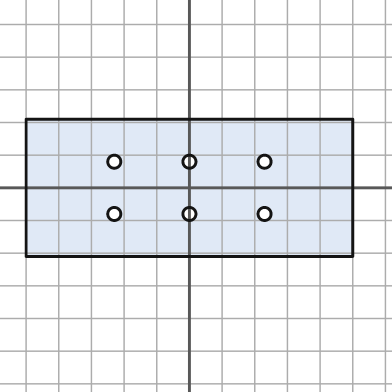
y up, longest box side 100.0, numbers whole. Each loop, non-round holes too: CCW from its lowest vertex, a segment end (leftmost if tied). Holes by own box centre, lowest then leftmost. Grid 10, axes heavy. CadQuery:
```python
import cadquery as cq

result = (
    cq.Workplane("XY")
    .moveTo(-50.0, -21.0)
    .lineTo(50.0, -21.0)
    .lineTo(50.0, 21.0)
    .lineTo(-50.0, 21.0)
    .close()
    .moveTo(-23.0, -8.0)
    .circle(2.0)
    .moveTo(0.0, -8.0)
    .circle(2.0)
    .moveTo(23.0, -8.0)
    .circle(2.0)
    .moveTo(-23.0, 8.0)
    .circle(2.0)
    .moveTo(0.0, 8.0)
    .circle(2.0)
    .moveTo(23.0, 8.0)
    .circle(2.0)
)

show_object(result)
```